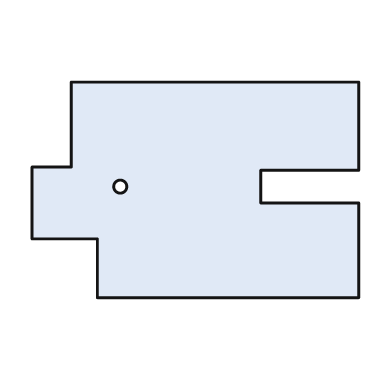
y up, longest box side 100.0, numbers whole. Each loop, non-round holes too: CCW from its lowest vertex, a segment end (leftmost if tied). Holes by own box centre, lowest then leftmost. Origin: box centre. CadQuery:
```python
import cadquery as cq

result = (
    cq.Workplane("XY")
    .moveTo(-30.0, -33.0)
    .lineTo(50.0, -33.0)
    .lineTo(50.0, -4.0)
    .lineTo(20.0, -4.0)
    .lineTo(20.0, 6.0)
    .lineTo(50.0, 6.0)
    .lineTo(50.0, 33.0)
    .lineTo(-38.0, 33.0)
    .lineTo(-38.0, 7.0)
    .lineTo(-50.0, 7.0)
    .lineTo(-50.0, -15.0)
    .lineTo(-30.0, -15.0)
    .close()
    .moveTo(-23.0, 1.0)
    .circle(2.0)
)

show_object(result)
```